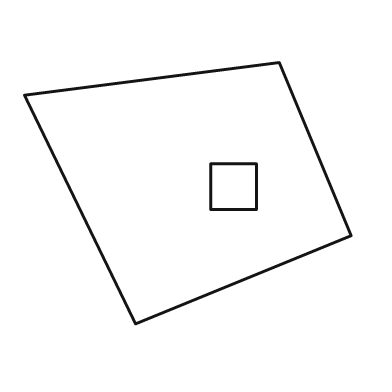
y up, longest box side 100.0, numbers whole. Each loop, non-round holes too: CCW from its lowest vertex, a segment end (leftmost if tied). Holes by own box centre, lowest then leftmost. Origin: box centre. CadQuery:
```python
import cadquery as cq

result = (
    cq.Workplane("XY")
    .moveTo(-16.0, -40.0)
    .lineTo(50.0, -13.0)
    .lineTo(28.0, 40.0)
    .lineTo(-50.0, 30.0)
    .close()
    .moveTo(7.0, -5.0)
    .lineTo(21.0, -5.0)
    .lineTo(21.0, 9.0)
    .lineTo(7.0, 9.0)
    .close()
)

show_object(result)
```